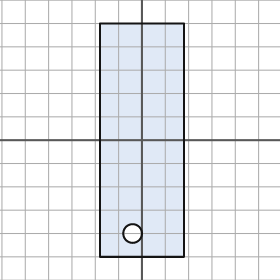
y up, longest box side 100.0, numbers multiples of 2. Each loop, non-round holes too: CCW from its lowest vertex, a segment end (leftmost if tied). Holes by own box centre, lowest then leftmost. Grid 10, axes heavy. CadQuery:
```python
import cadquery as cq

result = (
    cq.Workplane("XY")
    .moveTo(-18.0, -50.0)
    .lineTo(18.0, -50.0)
    .lineTo(18.0, 50.0)
    .lineTo(-18.0, 50.0)
    .close()
    .moveTo(-4.0, -40.0)
    .circle(4.0)
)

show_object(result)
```